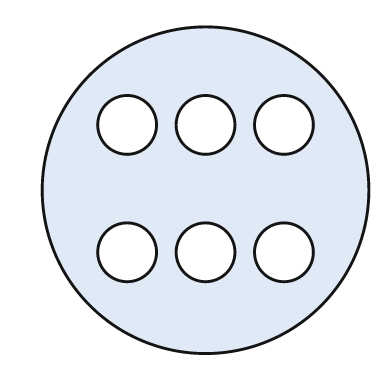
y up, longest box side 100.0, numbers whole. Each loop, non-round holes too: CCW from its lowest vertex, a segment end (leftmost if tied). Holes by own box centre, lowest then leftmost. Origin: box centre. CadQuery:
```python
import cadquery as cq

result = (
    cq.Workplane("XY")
    .moveTo(0.0, 0.0)
    .circle(50.0)
    .moveTo(-24.0, -19.0)
    .circle(9.0)
    .moveTo(0.0, -19.0)
    .circle(9.0)
    .moveTo(24.0, -19.0)
    .circle(9.0)
    .moveTo(-24.0, 20.0)
    .circle(9.0)
    .moveTo(0.0, 20.0)
    .circle(9.0)
    .moveTo(24.0, 20.0)
    .circle(9.0)
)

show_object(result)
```